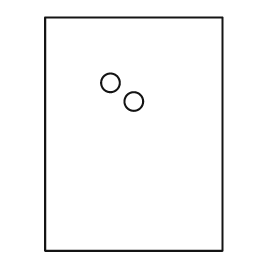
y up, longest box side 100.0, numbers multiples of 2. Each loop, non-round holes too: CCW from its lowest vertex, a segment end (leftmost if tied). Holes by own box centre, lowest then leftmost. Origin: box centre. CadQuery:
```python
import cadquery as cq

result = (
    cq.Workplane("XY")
    .moveTo(-38.0, -50.0)
    .lineTo(38.0, -50.0)
    .lineTo(38.0, 50.0)
    .lineTo(-38.0, 50.0)
    .close()
    .moveTo(0.0, 14.0)
    .circle(4.0)
    .moveTo(-10.0, 22.0)
    .circle(4.0)
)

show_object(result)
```